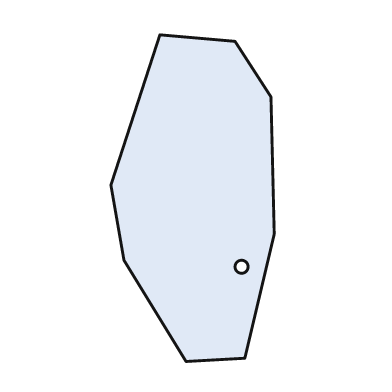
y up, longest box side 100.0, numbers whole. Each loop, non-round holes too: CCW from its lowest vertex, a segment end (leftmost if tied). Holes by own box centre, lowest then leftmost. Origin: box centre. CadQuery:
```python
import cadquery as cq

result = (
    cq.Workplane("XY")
    .moveTo(-2.0, -50.0)
    .lineTo(16.0, -49.0)
    .lineTo(25.0, -11.0)
    .lineTo(24.0, 31.0)
    .lineTo(13.0, 48.0)
    .lineTo(-10.0, 50.0)
    .lineTo(-25.0, 4.0)
    .lineTo(-21.0, -19.0)
    .close()
    .moveTo(15.0, -21.0)
    .circle(2.0)
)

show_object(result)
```